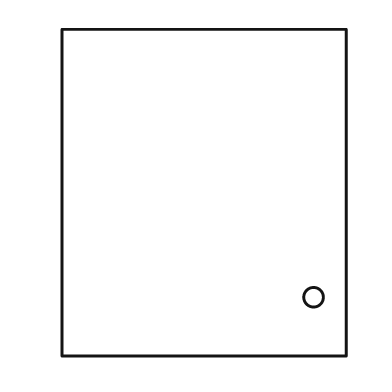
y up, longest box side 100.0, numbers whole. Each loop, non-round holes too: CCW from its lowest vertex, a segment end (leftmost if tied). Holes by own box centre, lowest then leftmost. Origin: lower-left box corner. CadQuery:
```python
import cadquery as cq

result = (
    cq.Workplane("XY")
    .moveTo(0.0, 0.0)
    .lineTo(87.0, 0.0)
    .lineTo(87.0, 100.0)
    .lineTo(0.0, 100.0)
    .close()
    .moveTo(77.0, 18.0)
    .circle(3.0)
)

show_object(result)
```